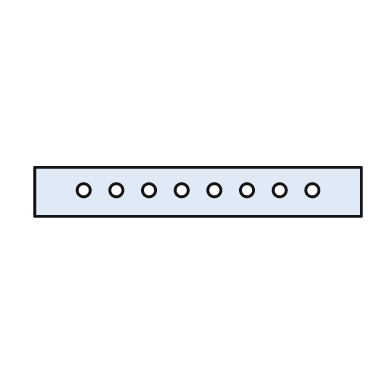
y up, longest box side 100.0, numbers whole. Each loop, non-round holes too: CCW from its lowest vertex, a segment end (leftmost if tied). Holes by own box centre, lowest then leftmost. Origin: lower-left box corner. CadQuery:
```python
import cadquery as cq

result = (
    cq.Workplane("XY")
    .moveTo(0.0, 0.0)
    .lineTo(100.0, 0.0)
    .lineTo(100.0, 15.0)
    .lineTo(0.0, 15.0)
    .close()
    .moveTo(15.0, 8.0)
    .circle(2.0)
    .moveTo(25.0, 8.0)
    .circle(2.0)
    .moveTo(35.0, 8.0)
    .circle(2.0)
    .moveTo(45.0, 8.0)
    .circle(2.0)
    .moveTo(55.0, 8.0)
    .circle(2.0)
    .moveTo(65.0, 8.0)
    .circle(2.0)
    .moveTo(75.0, 8.0)
    .circle(2.0)
    .moveTo(85.0, 8.0)
    .circle(2.0)
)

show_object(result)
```